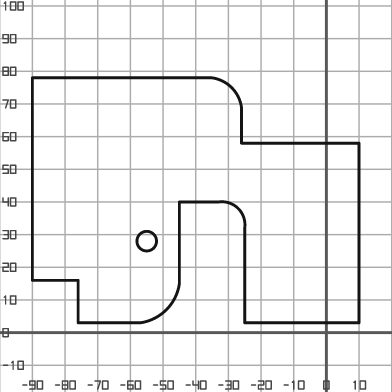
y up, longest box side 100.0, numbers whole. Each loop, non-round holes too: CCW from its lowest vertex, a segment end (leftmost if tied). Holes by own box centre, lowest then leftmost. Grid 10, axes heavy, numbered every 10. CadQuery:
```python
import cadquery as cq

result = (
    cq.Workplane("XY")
    .moveTo(-76.0, 3.0)
    .lineTo(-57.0, 3.0)
    .threePointArc((-49.0, 7.0), (-45.0, 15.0))
    .lineTo(-45.0, 40.0)
    .lineTo(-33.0, 40.0)
    .threePointArc((-27.0, 38.0), (-25.0, 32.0))
    .lineTo(-25.0, 3.0)
    .lineTo(10.0, 3.0)
    .lineTo(10.0, 58.0)
    .lineTo(-26.0, 58.0)
    .lineTo(-26.0, 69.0)
    .threePointArc((-29.0, 75.0), (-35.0, 78.0))
    .lineTo(-90.0, 78.0)
    .lineTo(-90.0, 16.0)
    .lineTo(-76.0, 16.0)
    .close()
    .moveTo(-55.0, 28.0)
    .circle(3.0)
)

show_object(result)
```